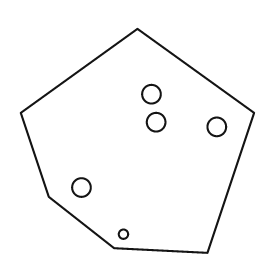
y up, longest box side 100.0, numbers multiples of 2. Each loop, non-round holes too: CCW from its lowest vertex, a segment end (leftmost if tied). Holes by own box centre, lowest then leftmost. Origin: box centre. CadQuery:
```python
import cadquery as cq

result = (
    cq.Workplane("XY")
    .moveTo(30.0, -48.0)
    .lineTo(50.0, 12.0)
    .lineTo(0.0, 48.0)
    .lineTo(-50.0, 12.0)
    .lineTo(-38.0, -24.0)
    .lineTo(-10.0, -46.0)
    .close()
    .moveTo(-6.0, -40.0)
    .circle(2.0)
    .moveTo(-24.0, -20.0)
    .circle(4.0)
    .moveTo(34.0, 6.0)
    .circle(4.0)
    .moveTo(8.0, 8.0)
    .circle(4.0)
    .moveTo(6.0, 20.0)
    .circle(4.0)
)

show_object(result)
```